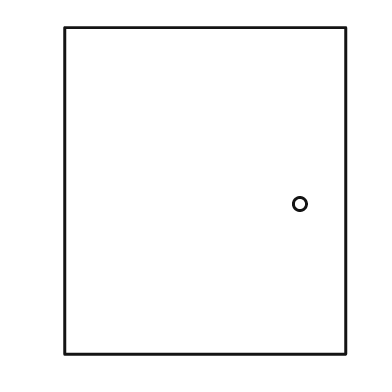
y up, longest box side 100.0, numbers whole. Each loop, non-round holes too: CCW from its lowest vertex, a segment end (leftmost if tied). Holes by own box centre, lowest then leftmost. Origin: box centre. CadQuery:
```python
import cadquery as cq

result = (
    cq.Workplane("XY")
    .moveTo(-43.0, -50.0)
    .lineTo(43.0, -50.0)
    .lineTo(43.0, 50.0)
    .lineTo(-43.0, 50.0)
    .close()
    .moveTo(29.0, -4.0)
    .circle(2.0)
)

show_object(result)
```